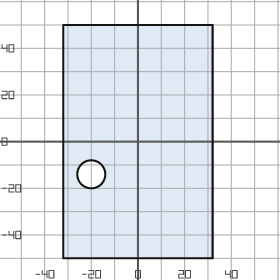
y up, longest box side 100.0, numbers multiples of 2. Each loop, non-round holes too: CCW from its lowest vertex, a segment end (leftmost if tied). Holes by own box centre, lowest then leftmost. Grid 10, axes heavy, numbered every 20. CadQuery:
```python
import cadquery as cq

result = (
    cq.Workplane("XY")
    .moveTo(-32.0, -50.0)
    .lineTo(32.0, -50.0)
    .lineTo(32.0, 50.0)
    .lineTo(-32.0, 50.0)
    .close()
    .moveTo(-20.0, -14.0)
    .circle(6.0)
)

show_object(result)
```